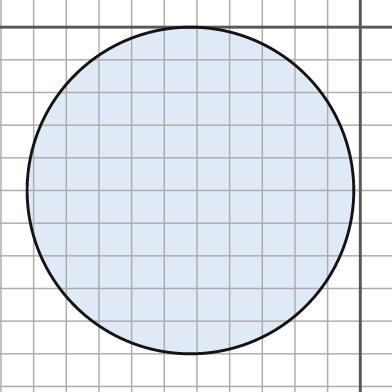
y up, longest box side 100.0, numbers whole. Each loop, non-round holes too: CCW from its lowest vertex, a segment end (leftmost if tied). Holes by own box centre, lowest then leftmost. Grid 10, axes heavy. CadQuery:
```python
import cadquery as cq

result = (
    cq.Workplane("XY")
    .moveTo(-52.0, -50.0)
    .circle(50.0)
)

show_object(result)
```